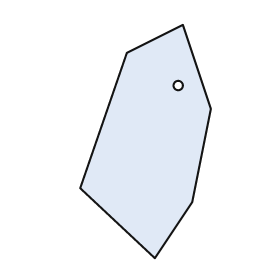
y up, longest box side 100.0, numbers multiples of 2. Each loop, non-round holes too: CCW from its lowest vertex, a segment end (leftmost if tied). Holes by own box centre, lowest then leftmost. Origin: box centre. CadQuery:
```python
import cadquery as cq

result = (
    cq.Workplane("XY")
    .moveTo(4.0, -50.0)
    .lineTo(20.0, -26.0)
    .lineTo(28.0, 14.0)
    .lineTo(16.0, 50.0)
    .lineTo(-8.0, 38.0)
    .lineTo(-28.0, -20.0)
    .close()
    .moveTo(14.0, 24.0)
    .circle(2.0)
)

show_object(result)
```